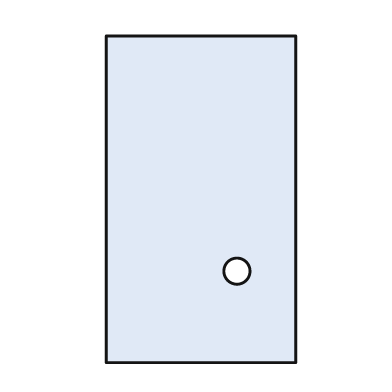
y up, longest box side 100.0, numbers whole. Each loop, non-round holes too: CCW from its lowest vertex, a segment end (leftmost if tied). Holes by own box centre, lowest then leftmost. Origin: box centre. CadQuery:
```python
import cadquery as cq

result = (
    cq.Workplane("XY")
    .moveTo(-29.0, -50.0)
    .lineTo(29.0, -50.0)
    .lineTo(29.0, 50.0)
    .lineTo(-29.0, 50.0)
    .close()
    .moveTo(11.0, -22.0)
    .circle(4.0)
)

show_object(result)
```